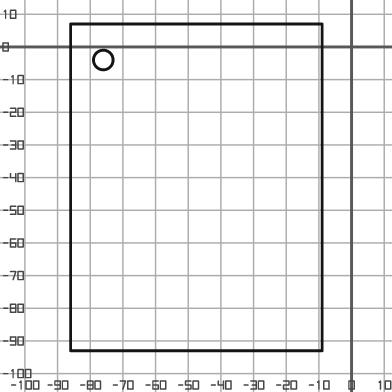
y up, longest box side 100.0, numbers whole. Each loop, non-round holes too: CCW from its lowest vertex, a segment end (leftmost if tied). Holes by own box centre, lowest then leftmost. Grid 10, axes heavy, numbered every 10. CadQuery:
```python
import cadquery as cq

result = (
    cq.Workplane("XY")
    .moveTo(-86.0, -93.0)
    .lineTo(-9.0, -93.0)
    .lineTo(-9.0, 7.0)
    .lineTo(-86.0, 7.0)
    .close()
    .moveTo(-76.0, -4.0)
    .circle(3.0)
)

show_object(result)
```